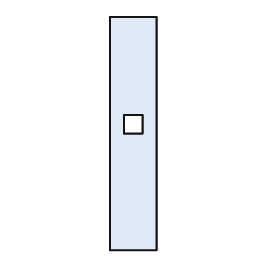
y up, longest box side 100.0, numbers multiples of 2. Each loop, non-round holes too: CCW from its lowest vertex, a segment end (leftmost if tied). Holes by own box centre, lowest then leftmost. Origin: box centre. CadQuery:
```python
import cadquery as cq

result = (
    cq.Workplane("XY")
    .moveTo(-10.0, -50.0)
    .lineTo(10.0, -50.0)
    .lineTo(10.0, 50.0)
    .lineTo(-10.0, 50.0)
    .close()
    .moveTo(-4.0, 0.0)
    .lineTo(4.0, 0.0)
    .lineTo(4.0, 8.0)
    .lineTo(-4.0, 8.0)
    .close()
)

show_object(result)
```